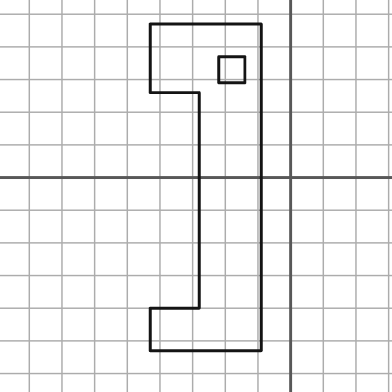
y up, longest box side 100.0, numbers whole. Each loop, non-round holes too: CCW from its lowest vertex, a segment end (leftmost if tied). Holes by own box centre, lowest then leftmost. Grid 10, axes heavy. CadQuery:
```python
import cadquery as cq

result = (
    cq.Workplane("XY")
    .moveTo(-43.0, -53.0)
    .lineTo(-9.0, -53.0)
    .lineTo(-9.0, 47.0)
    .lineTo(-43.0, 47.0)
    .lineTo(-43.0, 26.0)
    .lineTo(-28.0, 26.0)
    .lineTo(-28.0, -40.0)
    .lineTo(-43.0, -40.0)
    .close()
    .moveTo(-22.0, 29.0)
    .lineTo(-14.0, 29.0)
    .lineTo(-14.0, 37.0)
    .lineTo(-22.0, 37.0)
    .close()
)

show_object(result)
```